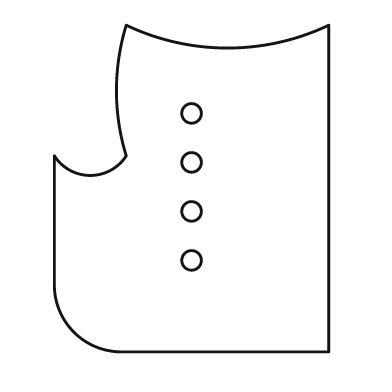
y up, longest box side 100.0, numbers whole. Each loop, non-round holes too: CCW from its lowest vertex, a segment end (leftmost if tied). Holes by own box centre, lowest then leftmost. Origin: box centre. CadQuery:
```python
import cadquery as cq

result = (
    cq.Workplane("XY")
    .moveTo(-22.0, -50.0)
    .lineTo(42.0, -50.0)
    .lineTo(42.0, 50.0)
    .threePointArc((11.0, 43.0), (-20.0, 50.0))
    .threePointArc((-23.0, 30.0), (-20.0, 10.0))
    .threePointArc((-31.0, 4.0), (-42.0, 10.0))
    .lineTo(-42.0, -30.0)
    .threePointArc((-36.0, -44.0), (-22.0, -50.0))
    .close()
    .moveTo(0.0, -22.0)
    .circle(3.0)
    .moveTo(0.0, -7.0)
    .circle(3.0)
    .moveTo(0.0, 8.0)
    .circle(3.0)
    .moveTo(0.0, 23.0)
    .circle(3.0)
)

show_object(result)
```